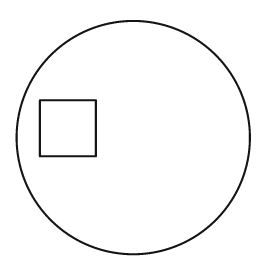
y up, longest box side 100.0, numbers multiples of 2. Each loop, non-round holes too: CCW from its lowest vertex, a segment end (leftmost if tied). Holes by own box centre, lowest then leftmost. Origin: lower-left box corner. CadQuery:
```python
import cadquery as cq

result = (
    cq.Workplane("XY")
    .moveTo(50.0, 50.0)
    .circle(50.0)
    .moveTo(10.0, 42.0)
    .lineTo(34.0, 42.0)
    .lineTo(34.0, 66.0)
    .lineTo(10.0, 66.0)
    .close()
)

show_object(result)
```